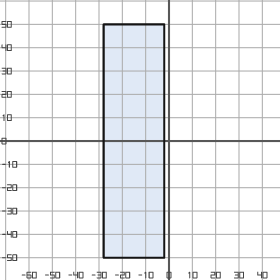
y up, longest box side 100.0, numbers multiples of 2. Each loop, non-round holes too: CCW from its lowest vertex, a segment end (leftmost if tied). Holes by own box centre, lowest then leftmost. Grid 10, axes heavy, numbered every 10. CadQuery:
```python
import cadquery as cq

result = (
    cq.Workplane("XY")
    .moveTo(-28.0, -50.0)
    .lineTo(-2.0, -50.0)
    .lineTo(-2.0, 50.0)
    .lineTo(-28.0, 50.0)
    .close()
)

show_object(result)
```